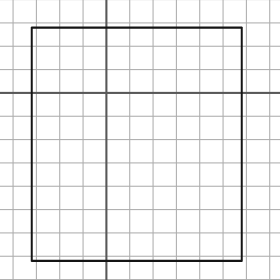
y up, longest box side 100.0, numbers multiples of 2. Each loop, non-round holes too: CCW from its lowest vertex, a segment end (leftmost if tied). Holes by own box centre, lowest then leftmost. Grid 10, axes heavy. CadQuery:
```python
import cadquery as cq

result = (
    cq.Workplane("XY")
    .moveTo(-32.0, -72.0)
    .lineTo(58.0, -72.0)
    .lineTo(58.0, 28.0)
    .lineTo(-32.0, 28.0)
    .close()
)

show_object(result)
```